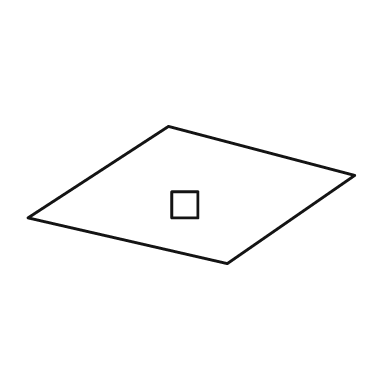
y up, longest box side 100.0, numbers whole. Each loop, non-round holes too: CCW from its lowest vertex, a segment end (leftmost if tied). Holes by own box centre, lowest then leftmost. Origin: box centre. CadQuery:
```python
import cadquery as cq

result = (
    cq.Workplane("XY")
    .moveTo(11.0, -21.0)
    .lineTo(50.0, 6.0)
    .lineTo(-7.0, 21.0)
    .lineTo(-50.0, -7.0)
    .close()
    .moveTo(-6.0, -7.0)
    .lineTo(2.0, -7.0)
    .lineTo(2.0, 1.0)
    .lineTo(-6.0, 1.0)
    .close()
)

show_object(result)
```